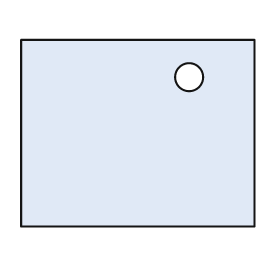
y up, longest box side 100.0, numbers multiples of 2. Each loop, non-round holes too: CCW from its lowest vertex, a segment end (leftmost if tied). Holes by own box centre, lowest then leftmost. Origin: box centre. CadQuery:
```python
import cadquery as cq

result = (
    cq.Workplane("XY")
    .moveTo(-50.0, -40.0)
    .lineTo(50.0, -40.0)
    .lineTo(50.0, 40.0)
    .lineTo(-50.0, 40.0)
    .close()
    .moveTo(22.0, 24.0)
    .circle(6.0)
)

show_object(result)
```